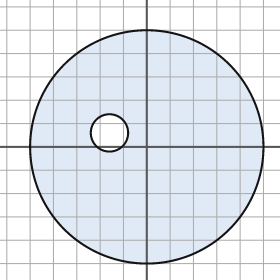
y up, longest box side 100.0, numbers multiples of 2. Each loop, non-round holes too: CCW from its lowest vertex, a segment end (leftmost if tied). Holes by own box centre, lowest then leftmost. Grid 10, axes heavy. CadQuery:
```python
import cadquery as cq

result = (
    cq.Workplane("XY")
    .moveTo(0.0, 0.0)
    .circle(50.0)
    .moveTo(-16.0, 6.0)
    .circle(8.0)
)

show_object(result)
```